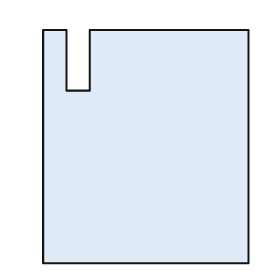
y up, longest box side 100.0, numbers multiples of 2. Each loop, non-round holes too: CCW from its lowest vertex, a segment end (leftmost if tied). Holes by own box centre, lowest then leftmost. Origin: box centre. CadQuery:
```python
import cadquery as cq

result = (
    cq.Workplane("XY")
    .moveTo(-44.0, -50.0)
    .lineTo(44.0, -50.0)
    .lineTo(44.0, 50.0)
    .lineTo(-24.0, 50.0)
    .lineTo(-24.0, 24.0)
    .lineTo(-34.0, 24.0)
    .lineTo(-34.0, 50.0)
    .lineTo(-44.0, 50.0)
    .close()
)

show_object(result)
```